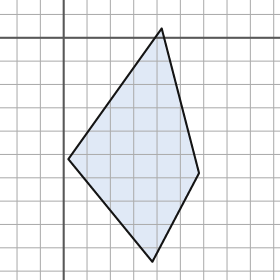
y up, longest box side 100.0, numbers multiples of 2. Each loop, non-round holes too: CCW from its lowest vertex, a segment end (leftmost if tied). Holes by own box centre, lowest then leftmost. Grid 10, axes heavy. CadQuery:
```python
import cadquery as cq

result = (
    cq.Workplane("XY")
    .moveTo(38.0, -96.0)
    .lineTo(58.0, -58.0)
    .lineTo(42.0, 4.0)
    .lineTo(2.0, -52.0)
    .close()
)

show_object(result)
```